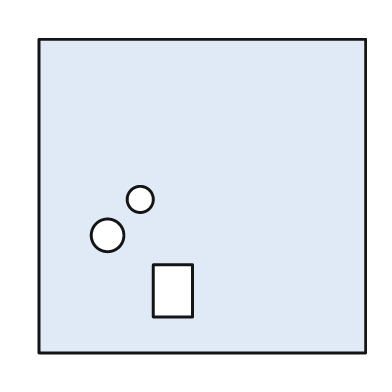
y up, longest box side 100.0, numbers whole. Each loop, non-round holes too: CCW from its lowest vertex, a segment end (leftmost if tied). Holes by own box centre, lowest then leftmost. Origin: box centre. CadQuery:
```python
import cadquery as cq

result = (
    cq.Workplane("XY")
    .moveTo(-50.0, -48.0)
    .lineTo(50.0, -48.0)
    .lineTo(50.0, 48.0)
    .lineTo(-50.0, 48.0)
    .close()
    .moveTo(-15.0, -37.0)
    .lineTo(-3.0, -37.0)
    .lineTo(-3.0, -21.0)
    .lineTo(-15.0, -21.0)
    .close()
    .moveTo(-29.0, -12.0)
    .circle(5.0)
    .moveTo(-19.0, -1.0)
    .circle(4.0)
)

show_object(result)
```